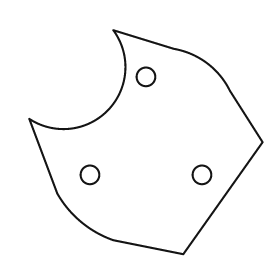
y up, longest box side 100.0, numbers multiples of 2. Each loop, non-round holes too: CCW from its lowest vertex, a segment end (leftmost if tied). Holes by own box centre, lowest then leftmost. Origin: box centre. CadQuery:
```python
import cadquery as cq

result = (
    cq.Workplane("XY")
    .moveTo(16.0, -48.0)
    .lineTo(50.0, 0.0)
    .lineTo(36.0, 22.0)
    .threePointArc((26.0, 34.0), (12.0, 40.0))
    .lineTo(-14.0, 48.0)
    .threePointArc((-16.0, 14.0), (-50.0, 10.0))
    .lineTo(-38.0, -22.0)
    .threePointArc((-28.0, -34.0), (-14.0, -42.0))
    .close()
    .moveTo(-24.0, -14.0)
    .circle(4.0)
    .moveTo(24.0, -14.0)
    .circle(4.0)
    .moveTo(0.0, 28.0)
    .circle(4.0)
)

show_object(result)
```